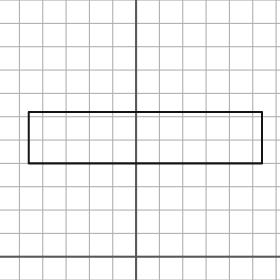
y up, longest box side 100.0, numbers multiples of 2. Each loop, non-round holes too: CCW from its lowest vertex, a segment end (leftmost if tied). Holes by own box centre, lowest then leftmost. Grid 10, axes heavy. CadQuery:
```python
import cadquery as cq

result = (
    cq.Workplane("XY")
    .moveTo(-46.0, 40.0)
    .lineTo(54.0, 40.0)
    .lineTo(54.0, 62.0)
    .lineTo(-46.0, 62.0)
    .close()
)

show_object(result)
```